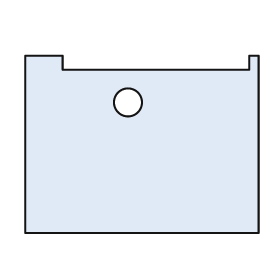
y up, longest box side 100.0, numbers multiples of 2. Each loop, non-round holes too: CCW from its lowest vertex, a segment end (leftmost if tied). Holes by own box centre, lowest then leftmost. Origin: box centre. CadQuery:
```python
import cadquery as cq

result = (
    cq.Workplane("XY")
    .moveTo(-50.0, -38.0)
    .lineTo(50.0, -38.0)
    .lineTo(50.0, 38.0)
    .lineTo(46.0, 38.0)
    .lineTo(46.0, 32.0)
    .lineTo(-34.0, 32.0)
    .lineTo(-34.0, 38.0)
    .lineTo(-50.0, 38.0)
    .close()
    .moveTo(-6.0, 18.0)
    .circle(6.0)
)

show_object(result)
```